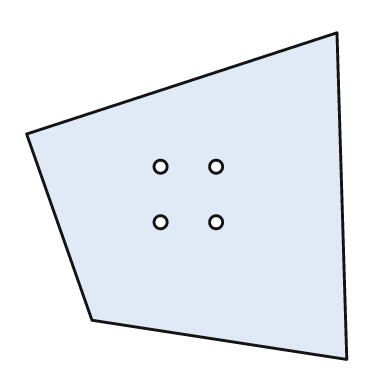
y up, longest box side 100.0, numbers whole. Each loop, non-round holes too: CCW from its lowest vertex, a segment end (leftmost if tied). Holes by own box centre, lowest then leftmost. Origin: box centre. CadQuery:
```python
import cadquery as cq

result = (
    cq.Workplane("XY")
    .moveTo(49.0, -50.0)
    .lineTo(46.0, 50.0)
    .lineTo(-49.0, 19.0)
    .lineTo(-29.0, -38.0)
    .close()
    .moveTo(-8.0, -8.0)
    .circle(2.0)
    .moveTo(9.0, -8.0)
    .circle(2.0)
    .moveTo(-8.0, 9.0)
    .circle(2.0)
    .moveTo(9.0, 9.0)
    .circle(2.0)
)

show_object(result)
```